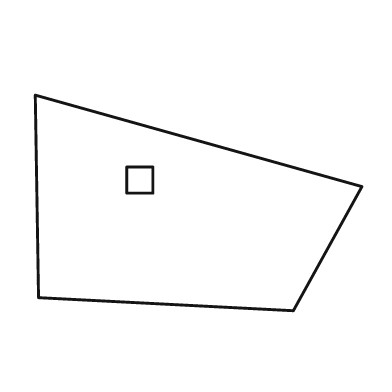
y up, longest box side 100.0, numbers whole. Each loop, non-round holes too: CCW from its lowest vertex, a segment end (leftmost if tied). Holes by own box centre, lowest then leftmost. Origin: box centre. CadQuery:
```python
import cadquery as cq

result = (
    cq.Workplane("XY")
    .moveTo(29.0, -33.0)
    .lineTo(50.0, 5.0)
    .lineTo(-50.0, 33.0)
    .lineTo(-49.0, -29.0)
    .close()
    .moveTo(-22.0, 3.0)
    .lineTo(-14.0, 3.0)
    .lineTo(-14.0, 11.0)
    .lineTo(-22.0, 11.0)
    .close()
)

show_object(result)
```